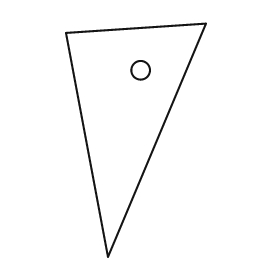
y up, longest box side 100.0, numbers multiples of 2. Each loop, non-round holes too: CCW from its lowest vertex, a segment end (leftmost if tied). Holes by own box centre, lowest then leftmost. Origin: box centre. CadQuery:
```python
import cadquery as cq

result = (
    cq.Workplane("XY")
    .moveTo(-12.0, -50.0)
    .lineTo(30.0, 50.0)
    .lineTo(-30.0, 46.0)
    .close()
    .moveTo(2.0, 30.0)
    .circle(4.0)
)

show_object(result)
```